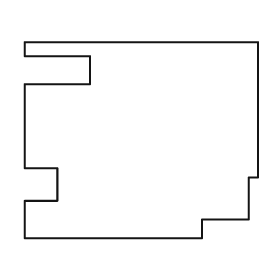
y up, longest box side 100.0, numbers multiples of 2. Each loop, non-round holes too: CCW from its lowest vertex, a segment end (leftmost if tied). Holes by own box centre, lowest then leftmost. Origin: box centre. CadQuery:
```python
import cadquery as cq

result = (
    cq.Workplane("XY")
    .moveTo(-50.0, -42.0)
    .lineTo(26.0, -42.0)
    .lineTo(26.0, -34.0)
    .lineTo(46.0, -34.0)
    .lineTo(46.0, -16.0)
    .lineTo(50.0, -16.0)
    .lineTo(50.0, 42.0)
    .lineTo(-50.0, 42.0)
    .lineTo(-50.0, 36.0)
    .lineTo(-22.0, 36.0)
    .lineTo(-22.0, 24.0)
    .lineTo(-50.0, 24.0)
    .lineTo(-50.0, -12.0)
    .lineTo(-36.0, -12.0)
    .lineTo(-36.0, -26.0)
    .lineTo(-50.0, -26.0)
    .close()
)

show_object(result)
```